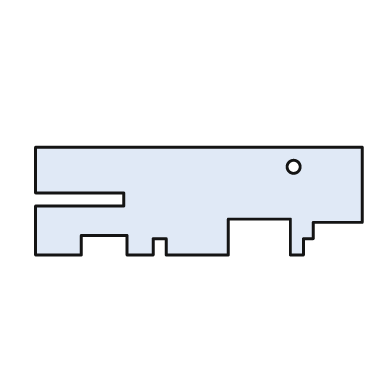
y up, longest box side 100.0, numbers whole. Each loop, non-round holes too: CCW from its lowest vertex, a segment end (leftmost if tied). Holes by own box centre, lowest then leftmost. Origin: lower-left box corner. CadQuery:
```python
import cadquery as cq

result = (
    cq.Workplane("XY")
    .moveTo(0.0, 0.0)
    .lineTo(14.0, 0.0)
    .lineTo(14.0, 6.0)
    .lineTo(28.0, 6.0)
    .lineTo(28.0, 0.0)
    .lineTo(36.0, 0.0)
    .lineTo(36.0, 5.0)
    .lineTo(40.0, 5.0)
    .lineTo(40.0, 0.0)
    .lineTo(59.0, 0.0)
    .lineTo(59.0, 11.0)
    .lineTo(78.0, 11.0)
    .lineTo(78.0, 0.0)
    .lineTo(82.0, 0.0)
    .lineTo(82.0, 5.0)
    .lineTo(85.0, 5.0)
    .lineTo(85.0, 10.0)
    .lineTo(100.0, 10.0)
    .lineTo(100.0, 33.0)
    .lineTo(0.0, 33.0)
    .lineTo(0.0, 19.0)
    .lineTo(27.0, 19.0)
    .lineTo(27.0, 15.0)
    .lineTo(0.0, 15.0)
    .close()
    .moveTo(79.0, 27.0)
    .circle(2.0)
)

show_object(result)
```